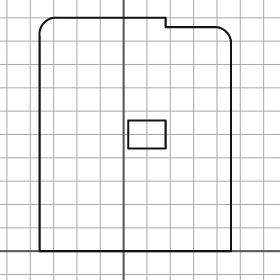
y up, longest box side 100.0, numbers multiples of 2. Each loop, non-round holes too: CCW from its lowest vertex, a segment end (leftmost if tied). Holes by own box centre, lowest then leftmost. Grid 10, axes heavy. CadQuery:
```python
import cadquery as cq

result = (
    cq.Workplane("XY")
    .moveTo(-36.0, 0.0)
    .lineTo(46.0, 0.0)
    .lineTo(46.0, 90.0)
    .threePointArc((44.0, 94.0), (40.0, 96.0))
    .lineTo(18.0, 96.0)
    .lineTo(18.0, 100.0)
    .lineTo(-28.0, 100.0)
    .threePointArc((-34.0, 98.0), (-36.0, 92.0))
    .close()
    .moveTo(2.0, 44.0)
    .lineTo(18.0, 44.0)
    .lineTo(18.0, 56.0)
    .lineTo(2.0, 56.0)
    .close()
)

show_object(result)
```